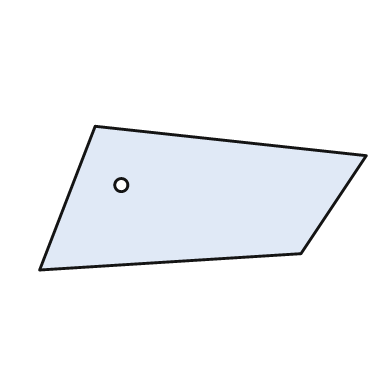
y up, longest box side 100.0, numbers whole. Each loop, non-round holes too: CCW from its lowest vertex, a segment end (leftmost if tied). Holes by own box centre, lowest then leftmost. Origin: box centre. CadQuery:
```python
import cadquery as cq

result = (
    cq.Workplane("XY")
    .moveTo(-50.0, -22.0)
    .lineTo(30.0, -17.0)
    .lineTo(50.0, 13.0)
    .lineTo(-33.0, 22.0)
    .close()
    .moveTo(-25.0, 4.0)
    .circle(2.0)
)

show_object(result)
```